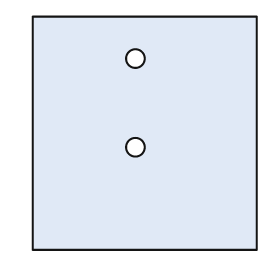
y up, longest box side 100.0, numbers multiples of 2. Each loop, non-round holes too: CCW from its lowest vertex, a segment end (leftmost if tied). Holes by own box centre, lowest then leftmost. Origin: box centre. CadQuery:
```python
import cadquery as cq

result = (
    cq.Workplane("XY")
    .moveTo(-48.0, -50.0)
    .lineTo(48.0, -50.0)
    .lineTo(48.0, 50.0)
    .lineTo(-48.0, 50.0)
    .close()
    .moveTo(-4.0, -6.0)
    .circle(4.0)
    .moveTo(-4.0, 32.0)
    .circle(4.0)
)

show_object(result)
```